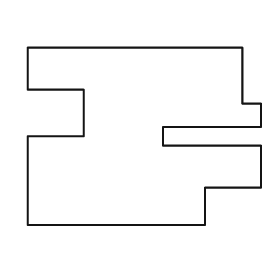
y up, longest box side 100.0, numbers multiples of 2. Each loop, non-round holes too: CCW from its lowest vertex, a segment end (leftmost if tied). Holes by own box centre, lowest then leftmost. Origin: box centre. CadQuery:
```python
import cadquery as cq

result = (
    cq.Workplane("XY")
    .moveTo(-50.0, -38.0)
    .lineTo(26.0, -38.0)
    .lineTo(26.0, -22.0)
    .lineTo(50.0, -22.0)
    .lineTo(50.0, -4.0)
    .lineTo(8.0, -4.0)
    .lineTo(8.0, 4.0)
    .lineTo(50.0, 4.0)
    .lineTo(50.0, 14.0)
    .lineTo(42.0, 14.0)
    .lineTo(42.0, 38.0)
    .lineTo(-50.0, 38.0)
    .lineTo(-50.0, 20.0)
    .lineTo(-26.0, 20.0)
    .lineTo(-26.0, 0.0)
    .lineTo(-50.0, 0.0)
    .close()
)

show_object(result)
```